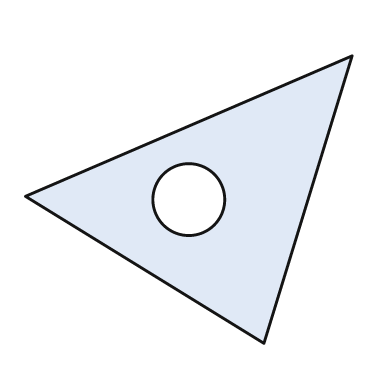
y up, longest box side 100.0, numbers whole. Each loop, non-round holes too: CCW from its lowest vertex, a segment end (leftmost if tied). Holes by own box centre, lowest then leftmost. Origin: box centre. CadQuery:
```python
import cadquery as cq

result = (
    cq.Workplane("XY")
    .moveTo(23.0, -44.0)
    .lineTo(50.0, 44.0)
    .lineTo(-50.0, 1.0)
    .close()
    .moveTo(0.0, 0.0)
    .circle(11.0)
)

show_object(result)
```